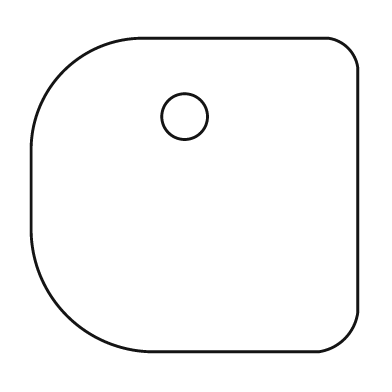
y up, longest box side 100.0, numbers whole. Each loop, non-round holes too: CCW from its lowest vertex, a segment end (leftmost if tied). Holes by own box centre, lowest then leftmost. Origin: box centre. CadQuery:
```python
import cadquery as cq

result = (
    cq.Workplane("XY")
    .moveTo(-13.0, -48.0)
    .lineTo(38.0, -48.0)
    .threePointArc((46.0, -44.0), (50.0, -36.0))
    .lineTo(50.0, 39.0)
    .threePointArc((47.0, 45.0), (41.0, 48.0))
    .lineTo(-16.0, 48.0)
    .threePointArc((-40.0, 38.0), (-50.0, 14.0))
    .lineTo(-50.0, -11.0)
    .threePointArc((-39.0, -37.0), (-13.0, -48.0))
    .close()
    .moveTo(-3.0, 24.0)
    .circle(7.0)
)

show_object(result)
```